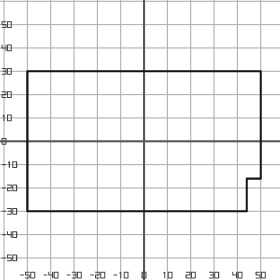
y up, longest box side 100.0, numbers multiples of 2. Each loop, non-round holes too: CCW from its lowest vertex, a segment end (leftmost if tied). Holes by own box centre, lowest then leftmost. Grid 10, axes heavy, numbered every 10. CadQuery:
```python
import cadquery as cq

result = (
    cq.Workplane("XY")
    .moveTo(-50.0, -30.0)
    .lineTo(44.0, -30.0)
    .lineTo(44.0, -16.0)
    .lineTo(50.0, -16.0)
    .lineTo(50.0, 30.0)
    .lineTo(-50.0, 30.0)
    .close()
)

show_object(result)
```